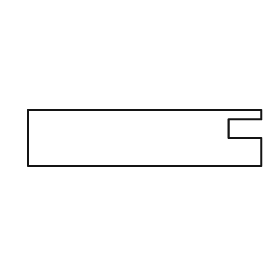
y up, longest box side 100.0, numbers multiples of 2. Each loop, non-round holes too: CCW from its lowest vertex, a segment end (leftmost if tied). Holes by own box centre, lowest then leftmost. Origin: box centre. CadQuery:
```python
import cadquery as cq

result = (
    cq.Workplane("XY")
    .moveTo(-50.0, -12.0)
    .lineTo(50.0, -12.0)
    .lineTo(50.0, 0.0)
    .lineTo(36.0, 0.0)
    .lineTo(36.0, 8.0)
    .lineTo(50.0, 8.0)
    .lineTo(50.0, 12.0)
    .lineTo(-50.0, 12.0)
    .close()
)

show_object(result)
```